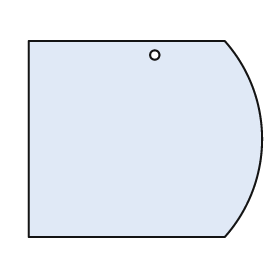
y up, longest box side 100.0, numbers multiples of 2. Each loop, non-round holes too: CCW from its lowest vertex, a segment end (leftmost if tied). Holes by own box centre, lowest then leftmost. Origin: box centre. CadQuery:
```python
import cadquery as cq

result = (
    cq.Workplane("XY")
    .moveTo(-50.0, -42.0)
    .lineTo(34.0, -42.0)
    .threePointArc((50.0, 0.0), (34.0, 42.0))
    .lineTo(-50.0, 42.0)
    .close()
    .moveTo(4.0, 36.0)
    .circle(2.0)
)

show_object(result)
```